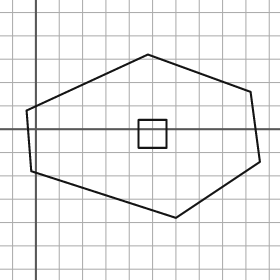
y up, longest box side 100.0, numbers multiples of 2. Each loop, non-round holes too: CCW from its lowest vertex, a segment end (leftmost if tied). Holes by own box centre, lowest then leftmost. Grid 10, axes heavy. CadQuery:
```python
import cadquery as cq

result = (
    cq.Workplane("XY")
    .moveTo(60.0, -38.0)
    .lineTo(96.0, -14.0)
    .lineTo(92.0, 16.0)
    .lineTo(48.0, 32.0)
    .lineTo(-4.0, 8.0)
    .lineTo(-2.0, -18.0)
    .close()
    .moveTo(44.0, -8.0)
    .lineTo(56.0, -8.0)
    .lineTo(56.0, 4.0)
    .lineTo(44.0, 4.0)
    .close()
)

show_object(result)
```